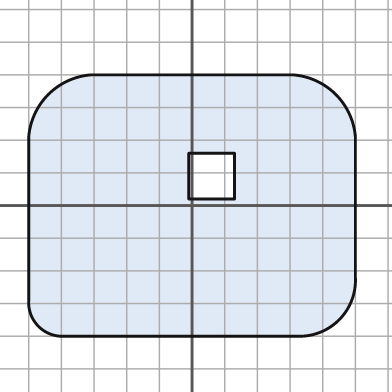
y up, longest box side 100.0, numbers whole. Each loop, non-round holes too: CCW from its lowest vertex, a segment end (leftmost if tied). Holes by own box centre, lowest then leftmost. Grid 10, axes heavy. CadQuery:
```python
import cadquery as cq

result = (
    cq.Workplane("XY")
    .moveTo(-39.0, -40.0)
    .lineTo(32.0, -40.0)
    .threePointArc((45.0, -35.0), (50.0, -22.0))
    .lineTo(50.0, 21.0)
    .threePointArc((44.0, 34.0), (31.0, 40.0))
    .lineTo(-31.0, 40.0)
    .threePointArc((-44.0, 34.0), (-50.0, 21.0))
    .lineTo(-50.0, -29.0)
    .threePointArc((-47.0, -37.0), (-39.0, -40.0))
    .close()
    .moveTo(-1.0, 2.0)
    .lineTo(13.0, 2.0)
    .lineTo(13.0, 16.0)
    .lineTo(-1.0, 16.0)
    .close()
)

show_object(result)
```